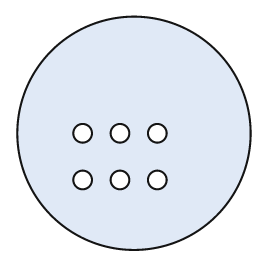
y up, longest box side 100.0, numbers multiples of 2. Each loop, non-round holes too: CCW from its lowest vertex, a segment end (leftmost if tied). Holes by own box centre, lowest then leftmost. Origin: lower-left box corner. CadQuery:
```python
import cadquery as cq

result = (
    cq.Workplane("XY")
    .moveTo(50.0, 50.0)
    .circle(50.0)
    .moveTo(28.0, 30.0)
    .circle(4.0)
    .moveTo(44.0, 30.0)
    .circle(4.0)
    .moveTo(60.0, 30.0)
    .circle(4.0)
    .moveTo(28.0, 50.0)
    .circle(4.0)
    .moveTo(44.0, 50.0)
    .circle(4.0)
    .moveTo(60.0, 50.0)
    .circle(4.0)
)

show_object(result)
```